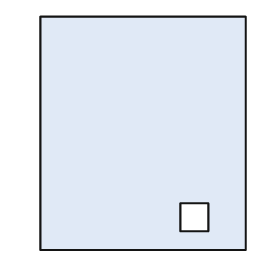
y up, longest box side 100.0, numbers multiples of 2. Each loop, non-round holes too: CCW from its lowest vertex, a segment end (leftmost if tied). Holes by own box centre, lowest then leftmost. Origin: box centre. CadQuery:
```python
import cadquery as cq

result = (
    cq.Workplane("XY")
    .moveTo(-44.0, -50.0)
    .lineTo(44.0, -50.0)
    .lineTo(44.0, 50.0)
    .lineTo(-44.0, 50.0)
    .close()
    .moveTo(16.0, -42.0)
    .lineTo(28.0, -42.0)
    .lineTo(28.0, -30.0)
    .lineTo(16.0, -30.0)
    .close()
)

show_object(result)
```